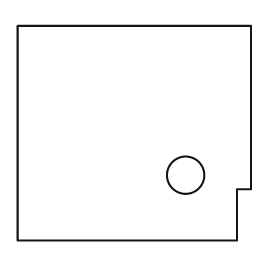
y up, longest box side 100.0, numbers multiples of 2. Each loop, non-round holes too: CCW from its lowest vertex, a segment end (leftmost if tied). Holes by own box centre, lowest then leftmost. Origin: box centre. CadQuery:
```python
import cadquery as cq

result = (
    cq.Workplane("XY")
    .moveTo(-50.0, -46.0)
    .lineTo(44.0, -46.0)
    .lineTo(44.0, -24.0)
    .lineTo(50.0, -24.0)
    .lineTo(50.0, 46.0)
    .lineTo(-50.0, 46.0)
    .close()
    .moveTo(22.0, -18.0)
    .circle(8.0)
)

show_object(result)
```